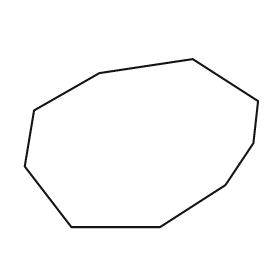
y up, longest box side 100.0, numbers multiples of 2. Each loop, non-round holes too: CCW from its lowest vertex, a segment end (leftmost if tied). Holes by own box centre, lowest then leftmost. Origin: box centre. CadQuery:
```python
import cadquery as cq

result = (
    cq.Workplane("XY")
    .moveTo(-30.0, -36.0)
    .lineTo(8.0, -36.0)
    .lineTo(36.0, -18.0)
    .lineTo(48.0, 0.0)
    .lineTo(50.0, 18.0)
    .lineTo(22.0, 36.0)
    .lineTo(-18.0, 30.0)
    .lineTo(-46.0, 14.0)
    .lineTo(-50.0, -10.0)
    .close()
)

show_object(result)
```